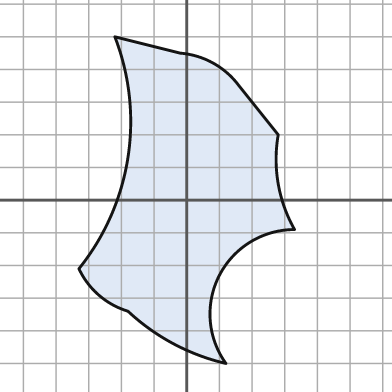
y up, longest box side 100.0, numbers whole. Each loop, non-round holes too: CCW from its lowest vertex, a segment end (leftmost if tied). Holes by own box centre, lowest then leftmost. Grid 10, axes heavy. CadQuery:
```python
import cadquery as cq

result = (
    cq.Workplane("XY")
    .moveTo(12.0, -50.0)
    .threePointArc((10.0, -23.0), (33.0, -9.0))
    .threePointArc((28.0, 5.0), (28.0, 20.0))
    .lineTo(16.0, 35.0)
    .threePointArc((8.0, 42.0), (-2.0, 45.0))
    .lineTo(-22.0, 50.0)
    .threePointArc((-18.0, 13.0), (-33.0, -21.0))
    .threePointArc((-27.0, -29.0), (-18.0, -34.0))
    .threePointArc((-4.0, -44.0), (12.0, -50.0))
    .close()
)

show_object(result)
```